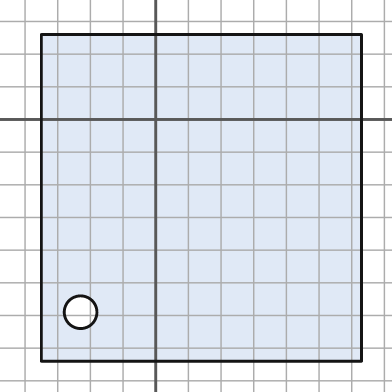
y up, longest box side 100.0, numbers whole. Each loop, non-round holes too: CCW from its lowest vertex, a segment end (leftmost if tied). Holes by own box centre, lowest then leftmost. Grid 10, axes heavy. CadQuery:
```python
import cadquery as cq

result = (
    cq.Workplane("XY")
    .moveTo(-35.0, -74.0)
    .lineTo(63.0, -74.0)
    .lineTo(63.0, 26.0)
    .lineTo(-35.0, 26.0)
    .close()
    .moveTo(-23.0, -59.0)
    .circle(5.0)
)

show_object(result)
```